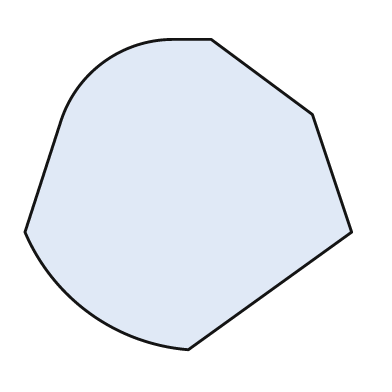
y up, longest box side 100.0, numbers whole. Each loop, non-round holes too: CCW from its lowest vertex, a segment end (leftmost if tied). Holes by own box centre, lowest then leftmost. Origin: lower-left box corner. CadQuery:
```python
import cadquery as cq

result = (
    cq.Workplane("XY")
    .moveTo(50.0, 0.0)
    .lineTo(100.0, 36.0)
    .lineTo(88.0, 72.0)
    .lineTo(57.0, 95.0)
    .lineTo(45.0, 95.0)
    .threePointArc((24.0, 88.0), (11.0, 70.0))
    .lineTo(0.0, 36.0)
    .threePointArc((20.0, 11.0), (50.0, 0.0))
    .close()
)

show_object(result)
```